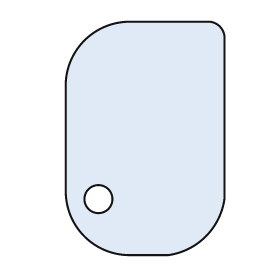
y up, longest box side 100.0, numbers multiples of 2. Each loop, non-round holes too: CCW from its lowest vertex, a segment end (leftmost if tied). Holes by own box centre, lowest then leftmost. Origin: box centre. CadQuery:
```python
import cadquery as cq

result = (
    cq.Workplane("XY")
    .moveTo(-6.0, -50.0)
    .lineTo(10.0, -50.0)
    .threePointArc((26.0, -42.0), (34.0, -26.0))
    .lineTo(34.0, 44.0)
    .threePointArc((32.0, 48.0), (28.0, 50.0))
    .lineTo(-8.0, 50.0)
    .threePointArc((-26.0, 42.0), (-34.0, 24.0))
    .lineTo(-34.0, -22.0)
    .threePointArc((-26.0, -42.0), (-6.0, -50.0))
    .close()
    .moveTo(-20.0, -26.0)
    .circle(6.0)
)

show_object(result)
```